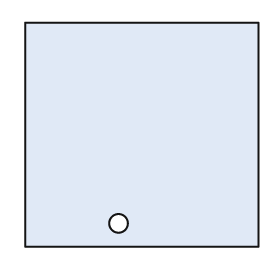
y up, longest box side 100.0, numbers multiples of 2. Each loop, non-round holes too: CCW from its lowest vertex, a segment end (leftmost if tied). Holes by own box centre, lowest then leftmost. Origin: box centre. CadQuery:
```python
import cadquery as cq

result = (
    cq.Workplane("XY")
    .moveTo(-50.0, -48.0)
    .lineTo(50.0, -48.0)
    .lineTo(50.0, 48.0)
    .lineTo(-50.0, 48.0)
    .close()
    .moveTo(-10.0, -38.0)
    .circle(4.0)
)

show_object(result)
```